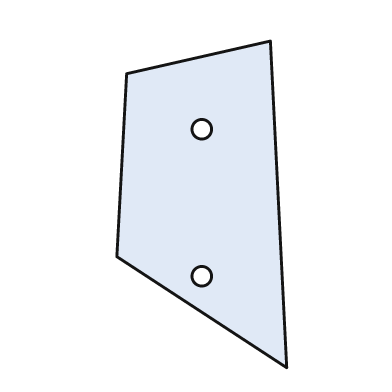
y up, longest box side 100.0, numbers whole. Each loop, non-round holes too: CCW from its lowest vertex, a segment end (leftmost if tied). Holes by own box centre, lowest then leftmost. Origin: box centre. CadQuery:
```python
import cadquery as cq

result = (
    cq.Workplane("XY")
    .moveTo(26.0, -50.0)
    .lineTo(21.0, 50.0)
    .lineTo(-23.0, 40.0)
    .lineTo(-26.0, -16.0)
    .close()
    .moveTo(0.0, -22.0)
    .circle(3.0)
    .moveTo(0.0, 23.0)
    .circle(3.0)
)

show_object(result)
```